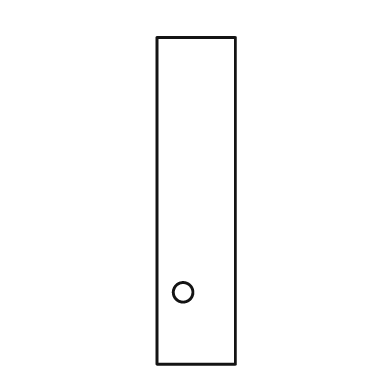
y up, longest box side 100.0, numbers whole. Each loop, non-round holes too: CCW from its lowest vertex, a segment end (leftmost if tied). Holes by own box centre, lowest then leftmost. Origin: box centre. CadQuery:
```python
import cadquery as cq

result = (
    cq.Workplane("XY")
    .moveTo(-12.0, -50.0)
    .lineTo(12.0, -50.0)
    .lineTo(12.0, 50.0)
    .lineTo(-12.0, 50.0)
    .close()
    .moveTo(-4.0, -28.0)
    .circle(3.0)
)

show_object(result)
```